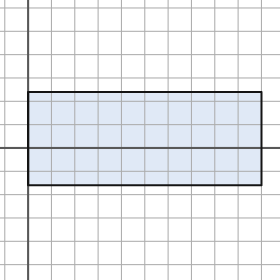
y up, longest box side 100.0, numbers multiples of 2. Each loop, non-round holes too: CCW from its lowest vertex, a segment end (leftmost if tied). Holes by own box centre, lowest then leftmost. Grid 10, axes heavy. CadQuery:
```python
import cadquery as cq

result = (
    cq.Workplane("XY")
    .moveTo(0.0, -16.0)
    .lineTo(100.0, -16.0)
    .lineTo(100.0, 24.0)
    .lineTo(0.0, 24.0)
    .close()
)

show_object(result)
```